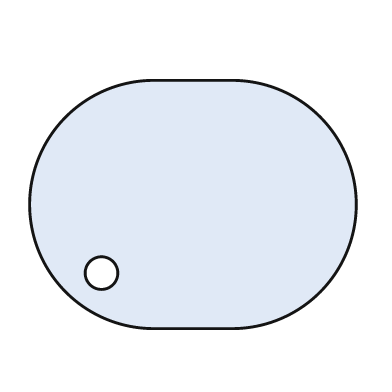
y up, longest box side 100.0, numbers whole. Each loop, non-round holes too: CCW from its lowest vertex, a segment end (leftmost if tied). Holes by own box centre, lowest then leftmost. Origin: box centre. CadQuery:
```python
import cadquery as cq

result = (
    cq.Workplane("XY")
    .moveTo(-12.0, -38.0)
    .lineTo(12.0, -38.0)
    .threePointArc((50.0, 0.0), (12.0, 38.0))
    .lineTo(-12.0, 38.0)
    .threePointArc((-50.0, 0.0), (-12.0, -38.0))
    .close()
    .moveTo(-28.0, -21.0)
    .circle(5.0)
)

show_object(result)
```